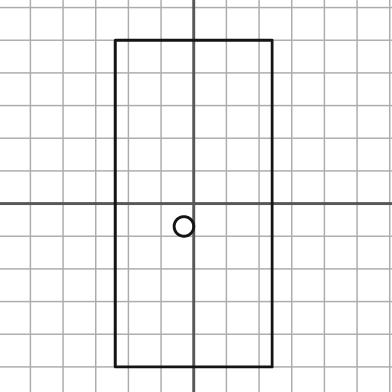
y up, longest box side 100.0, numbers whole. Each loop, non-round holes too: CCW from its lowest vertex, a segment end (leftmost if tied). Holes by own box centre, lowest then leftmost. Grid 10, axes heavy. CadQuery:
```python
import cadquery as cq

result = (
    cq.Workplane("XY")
    .moveTo(-24.0, -50.0)
    .lineTo(24.0, -50.0)
    .lineTo(24.0, 50.0)
    .lineTo(-24.0, 50.0)
    .close()
    .moveTo(-3.0, -7.0)
    .circle(3.0)
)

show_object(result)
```